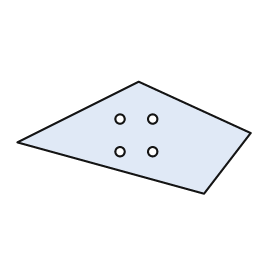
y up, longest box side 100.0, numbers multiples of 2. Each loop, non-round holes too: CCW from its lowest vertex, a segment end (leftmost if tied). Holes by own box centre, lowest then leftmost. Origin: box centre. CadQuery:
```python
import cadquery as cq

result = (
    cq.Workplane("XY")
    .moveTo(30.0, -24.0)
    .lineTo(50.0, 2.0)
    .lineTo(2.0, 24.0)
    .lineTo(-50.0, -2.0)
    .close()
    .moveTo(-6.0, -6.0)
    .circle(2.0)
    .moveTo(8.0, -6.0)
    .circle(2.0)
    .moveTo(-6.0, 8.0)
    .circle(2.0)
    .moveTo(8.0, 8.0)
    .circle(2.0)
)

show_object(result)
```